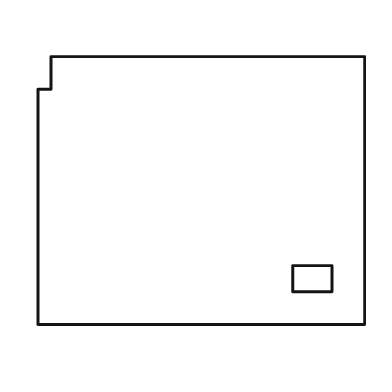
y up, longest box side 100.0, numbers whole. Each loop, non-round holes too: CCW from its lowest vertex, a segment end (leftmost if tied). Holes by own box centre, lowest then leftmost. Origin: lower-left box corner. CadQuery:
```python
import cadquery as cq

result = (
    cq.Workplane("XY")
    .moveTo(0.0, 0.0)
    .lineTo(100.0, 0.0)
    .lineTo(100.0, 82.0)
    .lineTo(4.0, 82.0)
    .lineTo(4.0, 72.0)
    .lineTo(0.0, 72.0)
    .close()
    .moveTo(78.0, 10.0)
    .lineTo(90.0, 10.0)
    .lineTo(90.0, 18.0)
    .lineTo(78.0, 18.0)
    .close()
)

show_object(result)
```